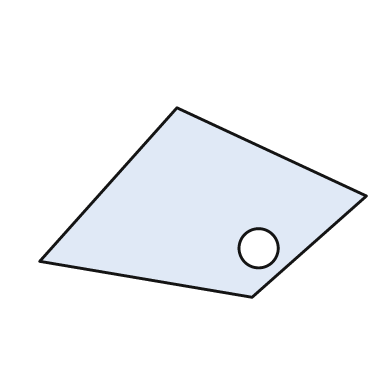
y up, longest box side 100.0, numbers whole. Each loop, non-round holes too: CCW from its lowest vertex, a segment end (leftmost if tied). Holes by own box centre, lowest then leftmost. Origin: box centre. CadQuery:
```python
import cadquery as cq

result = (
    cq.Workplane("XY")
    .moveTo(15.0, -29.0)
    .lineTo(50.0, 2.0)
    .lineTo(-8.0, 29.0)
    .lineTo(-50.0, -18.0)
    .close()
    .moveTo(17.0, -14.0)
    .circle(6.0)
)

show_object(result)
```